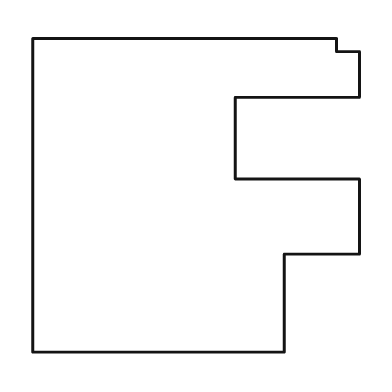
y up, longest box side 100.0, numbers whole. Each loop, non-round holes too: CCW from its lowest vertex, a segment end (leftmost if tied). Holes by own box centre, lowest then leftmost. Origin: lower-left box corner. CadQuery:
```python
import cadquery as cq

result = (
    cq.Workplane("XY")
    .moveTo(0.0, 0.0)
    .lineTo(77.0, 0.0)
    .lineTo(77.0, 30.0)
    .lineTo(100.0, 30.0)
    .lineTo(100.0, 53.0)
    .lineTo(62.0, 53.0)
    .lineTo(62.0, 78.0)
    .lineTo(100.0, 78.0)
    .lineTo(100.0, 92.0)
    .lineTo(93.0, 92.0)
    .lineTo(93.0, 96.0)
    .lineTo(0.0, 96.0)
    .close()
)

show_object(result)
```